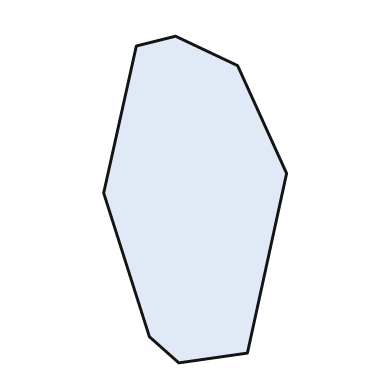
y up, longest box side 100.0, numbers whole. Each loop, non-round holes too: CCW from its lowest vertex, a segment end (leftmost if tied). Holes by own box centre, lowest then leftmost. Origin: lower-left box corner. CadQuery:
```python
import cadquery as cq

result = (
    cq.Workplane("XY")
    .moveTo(23.0, 0.0)
    .lineTo(44.0, 3.0)
    .lineTo(56.0, 58.0)
    .lineTo(41.0, 91.0)
    .lineTo(22.0, 100.0)
    .lineTo(10.0, 97.0)
    .lineTo(0.0, 52.0)
    .lineTo(14.0, 8.0)
    .close()
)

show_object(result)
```